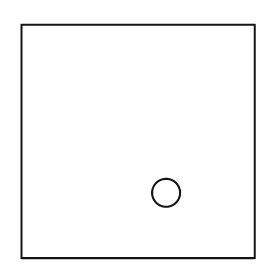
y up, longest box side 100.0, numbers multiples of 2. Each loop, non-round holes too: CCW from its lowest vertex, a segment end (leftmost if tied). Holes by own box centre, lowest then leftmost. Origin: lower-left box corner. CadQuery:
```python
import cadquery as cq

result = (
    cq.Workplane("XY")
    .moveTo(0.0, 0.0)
    .lineTo(100.0, 0.0)
    .lineTo(100.0, 100.0)
    .lineTo(0.0, 100.0)
    .close()
    .moveTo(62.0, 28.0)
    .circle(6.0)
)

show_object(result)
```